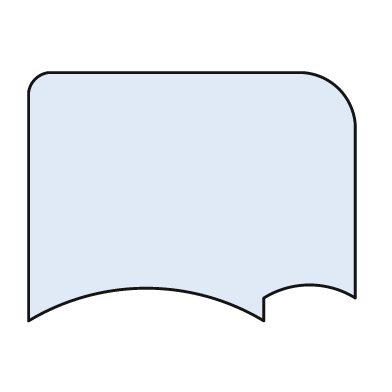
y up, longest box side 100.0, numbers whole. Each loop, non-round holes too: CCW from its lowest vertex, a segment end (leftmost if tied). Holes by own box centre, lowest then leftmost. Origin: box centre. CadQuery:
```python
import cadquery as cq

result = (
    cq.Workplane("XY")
    .moveTo(-50.0, -38.0)
    .threePointArc((-14.0, -28.0), (22.0, -38.0))
    .lineTo(22.0, -31.0)
    .threePointArc((36.0, -27.0), (50.0, -31.0))
    .lineTo(50.0, 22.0)
    .threePointArc((45.0, 33.0), (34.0, 38.0))
    .lineTo(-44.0, 38.0)
    .threePointArc((-48.0, 36.0), (-50.0, 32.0))
    .close()
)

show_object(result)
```